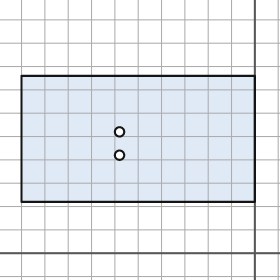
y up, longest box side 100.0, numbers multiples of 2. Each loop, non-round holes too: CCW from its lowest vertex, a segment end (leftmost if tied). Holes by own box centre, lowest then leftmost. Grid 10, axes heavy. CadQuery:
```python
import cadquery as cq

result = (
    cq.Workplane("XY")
    .moveTo(-100.0, 22.0)
    .lineTo(0.0, 22.0)
    .lineTo(0.0, 76.0)
    .lineTo(-100.0, 76.0)
    .close()
    .moveTo(-58.0, 42.0)
    .circle(2.0)
    .moveTo(-58.0, 52.0)
    .circle(2.0)
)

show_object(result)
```